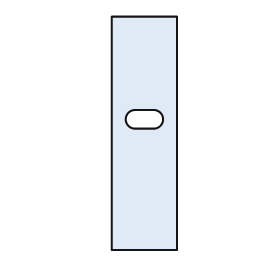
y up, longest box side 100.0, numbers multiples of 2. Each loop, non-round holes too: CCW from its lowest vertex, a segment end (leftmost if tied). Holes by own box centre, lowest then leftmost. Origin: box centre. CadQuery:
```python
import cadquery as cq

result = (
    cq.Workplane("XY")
    .moveTo(-14.0, -50.0)
    .lineTo(14.0, -50.0)
    .lineTo(14.0, 50.0)
    .lineTo(-14.0, 50.0)
    .close()
    .moveTo(-4.0, 2.0)
    .lineTo(4.0, 2.0)
    .threePointArc((8.0, 6.0), (4.0, 10.0))
    .lineTo(-4.0, 10.0)
    .threePointArc((-8.0, 6.0), (-4.0, 2.0))
    .close()
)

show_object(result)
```